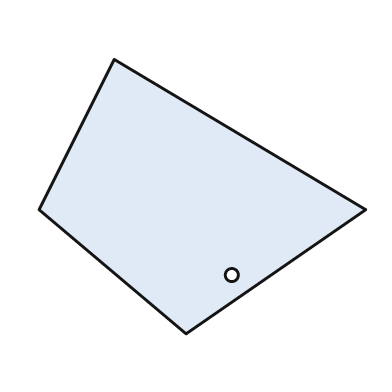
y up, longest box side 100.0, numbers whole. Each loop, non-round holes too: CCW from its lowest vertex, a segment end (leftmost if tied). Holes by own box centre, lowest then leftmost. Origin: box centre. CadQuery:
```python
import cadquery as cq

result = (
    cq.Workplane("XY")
    .moveTo(-5.0, -42.0)
    .lineTo(50.0, -4.0)
    .lineTo(-27.0, 42.0)
    .lineTo(-50.0, -4.0)
    .close()
    .moveTo(9.0, -24.0)
    .circle(2.0)
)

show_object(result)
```